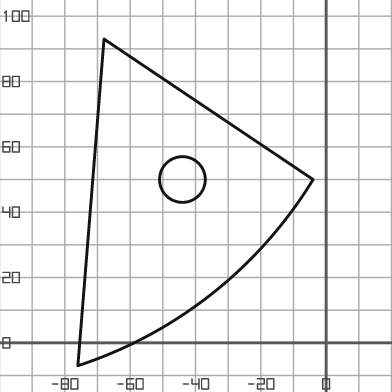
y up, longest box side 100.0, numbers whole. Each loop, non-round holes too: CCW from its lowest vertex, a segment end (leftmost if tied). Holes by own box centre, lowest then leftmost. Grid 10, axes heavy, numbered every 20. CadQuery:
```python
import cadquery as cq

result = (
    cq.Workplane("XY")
    .moveTo(-76.0, -7.0)
    .threePointArc((-35.0, 15.0), (-4.0, 50.0))
    .lineTo(-68.0, 93.0)
    .close()
    .moveTo(-44.0, 50.0)
    .circle(7.0)
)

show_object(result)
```